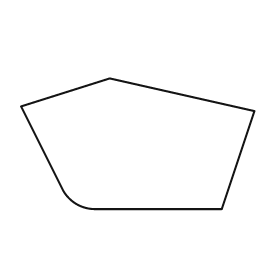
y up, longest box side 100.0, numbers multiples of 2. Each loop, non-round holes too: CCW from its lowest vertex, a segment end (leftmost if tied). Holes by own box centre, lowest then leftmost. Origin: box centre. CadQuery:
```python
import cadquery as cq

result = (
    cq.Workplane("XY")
    .moveTo(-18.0, -28.0)
    .lineTo(36.0, -28.0)
    .lineTo(50.0, 14.0)
    .lineTo(-12.0, 28.0)
    .lineTo(-50.0, 16.0)
    .lineTo(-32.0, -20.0)
    .threePointArc((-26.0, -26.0), (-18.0, -28.0))
    .close()
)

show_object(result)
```